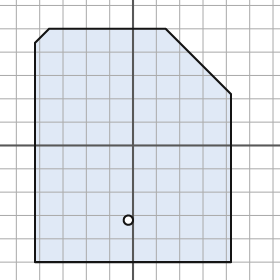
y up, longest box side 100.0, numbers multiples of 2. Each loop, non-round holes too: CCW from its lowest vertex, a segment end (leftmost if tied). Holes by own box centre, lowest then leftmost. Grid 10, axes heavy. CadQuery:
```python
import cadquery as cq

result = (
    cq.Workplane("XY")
    .moveTo(-42.0, -50.0)
    .lineTo(42.0, -50.0)
    .lineTo(42.0, 22.0)
    .lineTo(14.0, 50.0)
    .lineTo(-36.0, 50.0)
    .lineTo(-42.0, 44.0)
    .close()
    .moveTo(-2.0, -32.0)
    .circle(2.0)
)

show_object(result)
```